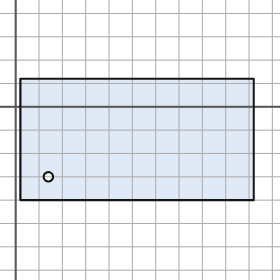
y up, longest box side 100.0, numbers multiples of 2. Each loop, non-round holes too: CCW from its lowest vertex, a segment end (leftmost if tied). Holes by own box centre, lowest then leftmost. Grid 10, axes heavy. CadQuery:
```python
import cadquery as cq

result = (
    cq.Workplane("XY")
    .moveTo(2.0, -40.0)
    .lineTo(102.0, -40.0)
    .lineTo(102.0, 12.0)
    .lineTo(2.0, 12.0)
    .close()
    .moveTo(14.0, -30.0)
    .circle(2.0)
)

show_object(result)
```